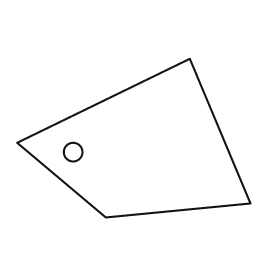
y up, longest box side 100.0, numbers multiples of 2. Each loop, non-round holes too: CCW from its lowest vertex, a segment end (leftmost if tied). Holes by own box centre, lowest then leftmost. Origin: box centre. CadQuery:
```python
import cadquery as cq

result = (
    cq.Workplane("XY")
    .moveTo(-12.0, -34.0)
    .lineTo(50.0, -28.0)
    .lineTo(24.0, 34.0)
    .lineTo(-50.0, -2.0)
    .close()
    .moveTo(-26.0, -6.0)
    .circle(4.0)
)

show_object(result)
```